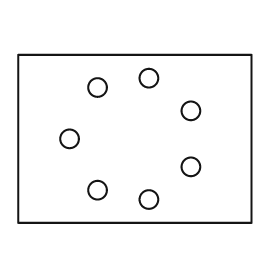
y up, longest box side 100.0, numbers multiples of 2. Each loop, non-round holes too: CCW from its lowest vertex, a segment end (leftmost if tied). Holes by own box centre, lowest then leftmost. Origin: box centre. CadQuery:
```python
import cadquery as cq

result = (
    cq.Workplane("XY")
    .moveTo(-50.0, -36.0)
    .lineTo(50.0, -36.0)
    .lineTo(50.0, 36.0)
    .lineTo(-50.0, 36.0)
    .close()
    .moveTo(6.0, -26.0)
    .circle(4.0)
    .moveTo(-16.0, -22.0)
    .circle(4.0)
    .moveTo(24.0, -12.0)
    .circle(4.0)
    .moveTo(-28.0, 0.0)
    .circle(4.0)
    .moveTo(24.0, 12.0)
    .circle(4.0)
    .moveTo(-16.0, 22.0)
    .circle(4.0)
    .moveTo(6.0, 26.0)
    .circle(4.0)
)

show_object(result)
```